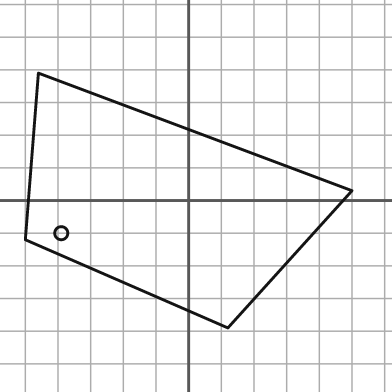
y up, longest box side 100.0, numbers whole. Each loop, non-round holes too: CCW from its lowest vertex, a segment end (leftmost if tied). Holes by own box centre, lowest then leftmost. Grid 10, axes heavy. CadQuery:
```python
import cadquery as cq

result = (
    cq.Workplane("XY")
    .moveTo(12.0, -39.0)
    .lineTo(50.0, 3.0)
    .lineTo(-46.0, 39.0)
    .lineTo(-50.0, -12.0)
    .close()
    .moveTo(-39.0, -10.0)
    .circle(2.0)
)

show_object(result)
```